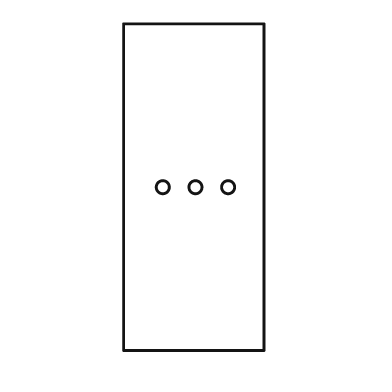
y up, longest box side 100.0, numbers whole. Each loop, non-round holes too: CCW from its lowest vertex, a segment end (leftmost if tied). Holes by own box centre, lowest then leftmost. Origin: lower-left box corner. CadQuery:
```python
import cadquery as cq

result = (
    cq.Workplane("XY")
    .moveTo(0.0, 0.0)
    .lineTo(43.0, 0.0)
    .lineTo(43.0, 100.0)
    .lineTo(0.0, 100.0)
    .close()
    .moveTo(12.0, 50.0)
    .circle(2.0)
    .moveTo(22.0, 50.0)
    .circle(2.0)
    .moveTo(32.0, 50.0)
    .circle(2.0)
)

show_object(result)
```